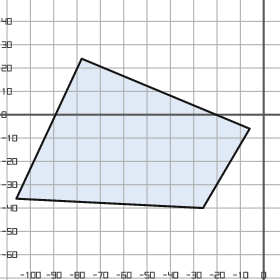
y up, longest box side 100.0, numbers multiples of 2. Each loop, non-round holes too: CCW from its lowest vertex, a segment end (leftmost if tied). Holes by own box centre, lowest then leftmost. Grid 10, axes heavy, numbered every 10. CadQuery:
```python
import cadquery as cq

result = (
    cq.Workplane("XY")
    .moveTo(-26.0, -40.0)
    .lineTo(-6.0, -6.0)
    .lineTo(-78.0, 24.0)
    .lineTo(-106.0, -36.0)
    .close()
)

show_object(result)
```